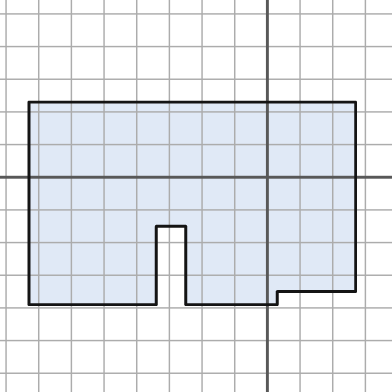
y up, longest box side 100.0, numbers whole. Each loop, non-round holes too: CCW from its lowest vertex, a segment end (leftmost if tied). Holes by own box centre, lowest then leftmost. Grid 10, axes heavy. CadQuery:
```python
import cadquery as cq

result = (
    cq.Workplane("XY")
    .moveTo(-73.0, -39.0)
    .lineTo(-34.0, -39.0)
    .lineTo(-34.0, -15.0)
    .lineTo(-25.0, -15.0)
    .lineTo(-25.0, -39.0)
    .lineTo(3.0, -39.0)
    .lineTo(3.0, -35.0)
    .lineTo(27.0, -35.0)
    .lineTo(27.0, 23.0)
    .lineTo(-73.0, 23.0)
    .close()
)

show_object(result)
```